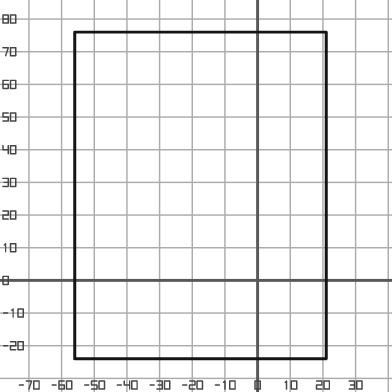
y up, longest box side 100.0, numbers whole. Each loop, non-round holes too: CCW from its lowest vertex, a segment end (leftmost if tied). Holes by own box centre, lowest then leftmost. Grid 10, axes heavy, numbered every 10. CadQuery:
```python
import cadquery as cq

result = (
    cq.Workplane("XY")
    .moveTo(-56.0, -24.0)
    .lineTo(21.0, -24.0)
    .lineTo(21.0, 76.0)
    .lineTo(-56.0, 76.0)
    .close()
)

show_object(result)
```